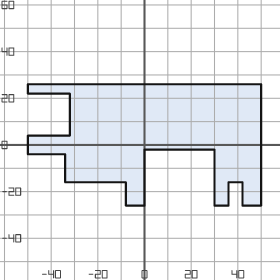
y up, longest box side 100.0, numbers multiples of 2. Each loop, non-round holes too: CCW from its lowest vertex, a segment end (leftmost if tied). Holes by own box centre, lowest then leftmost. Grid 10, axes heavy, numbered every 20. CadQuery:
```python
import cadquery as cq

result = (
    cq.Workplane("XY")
    .moveTo(-8.0, -26.0)
    .lineTo(0.0, -26.0)
    .lineTo(0.0, -2.0)
    .lineTo(30.0, -2.0)
    .lineTo(30.0, -26.0)
    .lineTo(36.0, -26.0)
    .lineTo(36.0, -16.0)
    .lineTo(42.0, -16.0)
    .lineTo(42.0, -26.0)
    .lineTo(50.0, -26.0)
    .lineTo(50.0, 26.0)
    .lineTo(-50.0, 26.0)
    .lineTo(-50.0, 22.0)
    .lineTo(-32.0, 22.0)
    .lineTo(-32.0, 4.0)
    .lineTo(-50.0, 4.0)
    .lineTo(-50.0, -4.0)
    .lineTo(-34.0, -4.0)
    .lineTo(-34.0, -16.0)
    .lineTo(-8.0, -16.0)
    .close()
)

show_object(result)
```